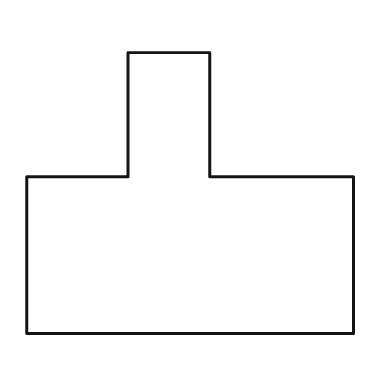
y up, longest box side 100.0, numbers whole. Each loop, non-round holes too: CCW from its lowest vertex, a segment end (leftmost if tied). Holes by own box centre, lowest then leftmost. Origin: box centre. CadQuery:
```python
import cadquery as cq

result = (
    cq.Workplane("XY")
    .moveTo(-50.0, -43.0)
    .lineTo(50.0, -43.0)
    .lineTo(50.0, 5.0)
    .lineTo(6.0, 5.0)
    .lineTo(6.0, 43.0)
    .lineTo(-19.0, 43.0)
    .lineTo(-19.0, 5.0)
    .lineTo(-50.0, 5.0)
    .close()
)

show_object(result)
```